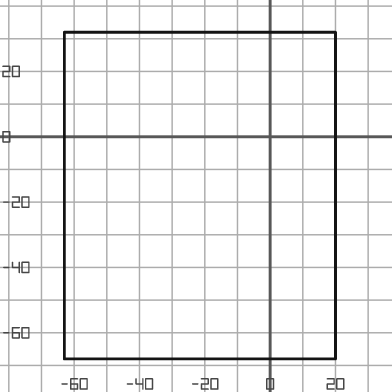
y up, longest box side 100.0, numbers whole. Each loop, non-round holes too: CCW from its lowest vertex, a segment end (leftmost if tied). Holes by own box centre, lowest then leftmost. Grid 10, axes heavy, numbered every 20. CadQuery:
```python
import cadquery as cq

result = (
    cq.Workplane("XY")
    .moveTo(-63.0, -68.0)
    .lineTo(20.0, -68.0)
    .lineTo(20.0, 32.0)
    .lineTo(-63.0, 32.0)
    .close()
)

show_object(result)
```